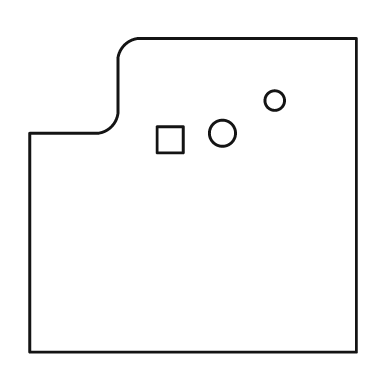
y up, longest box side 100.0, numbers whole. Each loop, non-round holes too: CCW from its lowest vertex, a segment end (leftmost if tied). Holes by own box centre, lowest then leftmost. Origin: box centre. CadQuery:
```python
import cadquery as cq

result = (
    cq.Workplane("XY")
    .moveTo(-50.0, -48.0)
    .lineTo(50.0, -48.0)
    .lineTo(50.0, 48.0)
    .lineTo(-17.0, 48.0)
    .threePointArc((-21.0, 46.0), (-23.0, 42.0))
    .lineTo(-23.0, 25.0)
    .threePointArc((-25.0, 21.0), (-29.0, 19.0))
    .lineTo(-50.0, 19.0)
    .close()
    .moveTo(-11.0, 13.0)
    .lineTo(-3.0, 13.0)
    .lineTo(-3.0, 21.0)
    .lineTo(-11.0, 21.0)
    .close()
    .moveTo(9.0, 19.0)
    .circle(4.0)
    .moveTo(25.0, 29.0)
    .circle(3.0)
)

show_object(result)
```